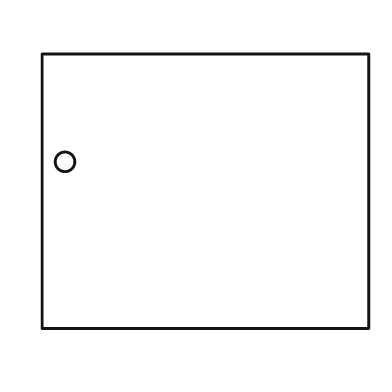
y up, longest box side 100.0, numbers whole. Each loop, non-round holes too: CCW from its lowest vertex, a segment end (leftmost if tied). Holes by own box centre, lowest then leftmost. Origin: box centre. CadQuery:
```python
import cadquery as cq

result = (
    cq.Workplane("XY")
    .moveTo(-50.0, -42.0)
    .lineTo(50.0, -42.0)
    .lineTo(50.0, 42.0)
    .lineTo(-50.0, 42.0)
    .close()
    .moveTo(-43.0, 9.0)
    .circle(3.0)
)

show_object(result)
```